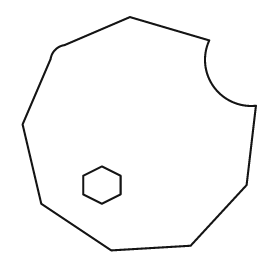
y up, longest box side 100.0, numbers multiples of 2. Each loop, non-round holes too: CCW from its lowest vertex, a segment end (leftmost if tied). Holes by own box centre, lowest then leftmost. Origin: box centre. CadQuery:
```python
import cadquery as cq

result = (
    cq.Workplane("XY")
    .moveTo(-12.0, -50.0)
    .lineTo(22.0, -48.0)
    .lineTo(46.0, -22.0)
    .lineTo(50.0, 12.0)
    .threePointArc((32.0, 20.0), (30.0, 40.0))
    .lineTo(-4.0, 50.0)
    .lineTo(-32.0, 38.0)
    .threePointArc((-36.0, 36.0), (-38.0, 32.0))
    .lineTo(-50.0, 4.0)
    .lineTo(-42.0, -30.0)
    .close()
    .moveTo(-16.0, -30.0)
    .lineTo(-8.0, -26.0)
    .lineTo(-8.0, -18.0)
    .lineTo(-16.0, -14.0)
    .lineTo(-24.0, -18.0)
    .lineTo(-24.0, -26.0)
    .close()
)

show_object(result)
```